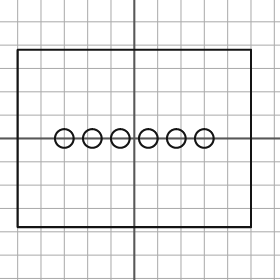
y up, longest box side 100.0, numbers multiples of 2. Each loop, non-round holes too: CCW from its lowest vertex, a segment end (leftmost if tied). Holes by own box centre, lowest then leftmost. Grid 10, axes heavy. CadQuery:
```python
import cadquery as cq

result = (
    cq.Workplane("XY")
    .moveTo(-50.0, -38.0)
    .lineTo(50.0, -38.0)
    .lineTo(50.0, 38.0)
    .lineTo(-50.0, 38.0)
    .close()
    .moveTo(-30.0, 0.0)
    .circle(4.0)
    .moveTo(-18.0, 0.0)
    .circle(4.0)
    .moveTo(-6.0, 0.0)
    .circle(4.0)
    .moveTo(6.0, 0.0)
    .circle(4.0)
    .moveTo(18.0, 0.0)
    .circle(4.0)
    .moveTo(30.0, 0.0)
    .circle(4.0)
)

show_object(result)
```